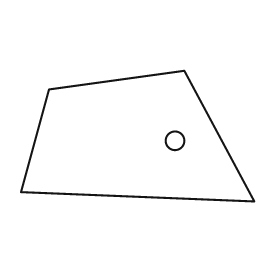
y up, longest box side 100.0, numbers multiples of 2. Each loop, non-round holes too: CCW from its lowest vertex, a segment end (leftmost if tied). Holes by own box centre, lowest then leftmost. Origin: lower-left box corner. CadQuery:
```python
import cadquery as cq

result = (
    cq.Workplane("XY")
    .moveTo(100.0, 0.0)
    .lineTo(70.0, 56.0)
    .lineTo(12.0, 48.0)
    .lineTo(0.0, 4.0)
    .close()
    .moveTo(66.0, 26.0)
    .circle(4.0)
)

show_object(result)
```